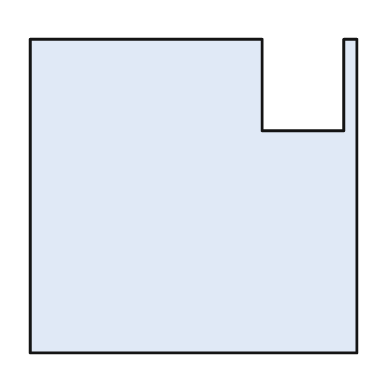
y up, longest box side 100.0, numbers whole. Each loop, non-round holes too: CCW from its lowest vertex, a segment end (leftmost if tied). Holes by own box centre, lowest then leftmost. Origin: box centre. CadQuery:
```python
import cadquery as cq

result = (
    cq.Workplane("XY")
    .moveTo(-50.0, -48.0)
    .lineTo(50.0, -48.0)
    .lineTo(50.0, 48.0)
    .lineTo(46.0, 48.0)
    .lineTo(46.0, 20.0)
    .lineTo(21.0, 20.0)
    .lineTo(21.0, 48.0)
    .lineTo(-50.0, 48.0)
    .close()
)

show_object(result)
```